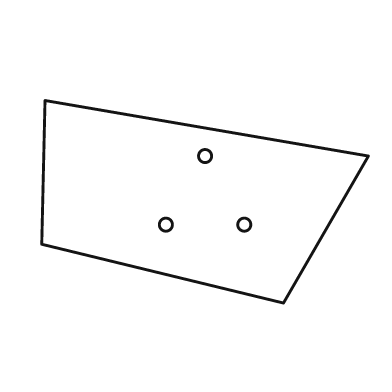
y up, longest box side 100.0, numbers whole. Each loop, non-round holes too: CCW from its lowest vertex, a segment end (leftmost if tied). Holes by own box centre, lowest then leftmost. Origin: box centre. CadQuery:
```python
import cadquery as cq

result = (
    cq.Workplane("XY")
    .moveTo(24.0, -31.0)
    .lineTo(50.0, 14.0)
    .lineTo(-49.0, 31.0)
    .lineTo(-50.0, -13.0)
    .close()
    .moveTo(-12.0, -7.0)
    .circle(2.0)
    .moveTo(12.0, -7.0)
    .circle(2.0)
    .moveTo(0.0, 14.0)
    .circle(2.0)
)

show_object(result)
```